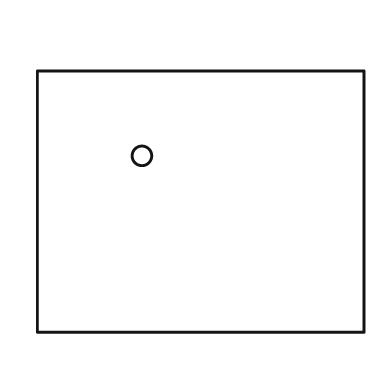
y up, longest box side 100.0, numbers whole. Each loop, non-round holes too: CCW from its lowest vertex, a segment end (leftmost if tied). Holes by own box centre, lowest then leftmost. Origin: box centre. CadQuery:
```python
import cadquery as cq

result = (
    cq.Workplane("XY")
    .moveTo(-50.0, -40.0)
    .lineTo(50.0, -40.0)
    .lineTo(50.0, 40.0)
    .lineTo(-50.0, 40.0)
    .close()
    .moveTo(-18.0, 14.0)
    .circle(3.0)
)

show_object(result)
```